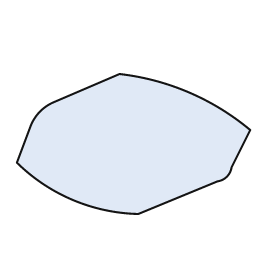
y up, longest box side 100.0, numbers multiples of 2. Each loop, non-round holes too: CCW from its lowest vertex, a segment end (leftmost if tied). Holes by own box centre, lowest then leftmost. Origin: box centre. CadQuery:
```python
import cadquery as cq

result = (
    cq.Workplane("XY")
    .moveTo(2.0, -30.0)
    .lineTo(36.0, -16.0)
    .threePointArc((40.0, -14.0), (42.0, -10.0))
    .lineTo(50.0, 6.0)
    .threePointArc((24.0, 22.0), (-6.0, 30.0))
    .lineTo(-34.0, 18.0)
    .threePointArc((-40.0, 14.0), (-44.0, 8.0))
    .lineTo(-50.0, -8.0)
    .threePointArc((-26.0, -24.0), (2.0, -30.0))
    .close()
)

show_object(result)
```